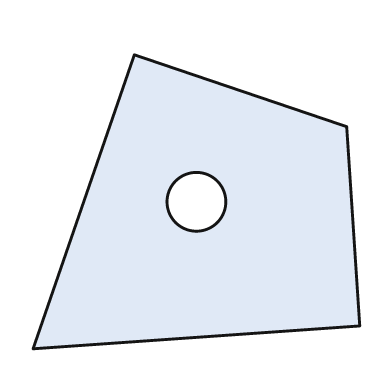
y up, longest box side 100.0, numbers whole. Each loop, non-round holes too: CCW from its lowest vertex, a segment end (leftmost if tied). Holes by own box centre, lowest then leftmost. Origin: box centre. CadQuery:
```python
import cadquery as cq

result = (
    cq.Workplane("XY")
    .moveTo(-50.0, -45.0)
    .lineTo(50.0, -38.0)
    .lineTo(46.0, 23.0)
    .lineTo(-19.0, 45.0)
    .close()
    .moveTo(0.0, 0.0)
    .circle(9.0)
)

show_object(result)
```